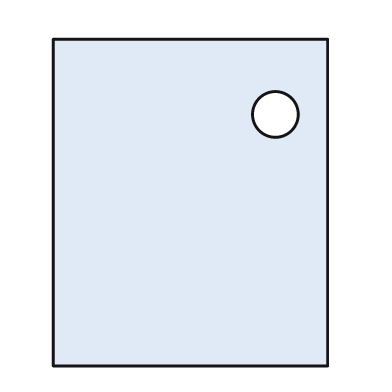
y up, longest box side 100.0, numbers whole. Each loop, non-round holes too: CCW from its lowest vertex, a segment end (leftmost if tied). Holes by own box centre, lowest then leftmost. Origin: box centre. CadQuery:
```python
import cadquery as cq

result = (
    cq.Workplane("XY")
    .moveTo(-42.0, -50.0)
    .lineTo(42.0, -50.0)
    .lineTo(42.0, 50.0)
    .lineTo(-42.0, 50.0)
    .close()
    .moveTo(26.0, 27.0)
    .circle(7.0)
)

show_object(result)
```